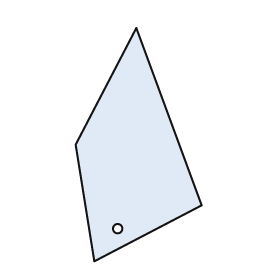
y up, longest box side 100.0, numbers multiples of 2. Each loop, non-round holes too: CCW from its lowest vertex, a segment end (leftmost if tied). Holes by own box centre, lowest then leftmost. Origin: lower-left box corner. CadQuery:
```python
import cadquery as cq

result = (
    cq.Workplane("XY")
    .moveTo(8.0, 0.0)
    .lineTo(54.0, 24.0)
    .lineTo(26.0, 100.0)
    .lineTo(0.0, 50.0)
    .close()
    .moveTo(18.0, 14.0)
    .circle(2.0)
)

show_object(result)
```